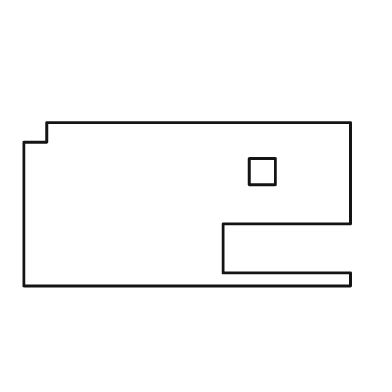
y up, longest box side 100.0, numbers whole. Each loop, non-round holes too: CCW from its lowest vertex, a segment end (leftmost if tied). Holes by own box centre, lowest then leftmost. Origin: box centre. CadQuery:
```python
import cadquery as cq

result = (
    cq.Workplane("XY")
    .moveTo(-50.0, -25.0)
    .lineTo(50.0, -25.0)
    .lineTo(50.0, -21.0)
    .lineTo(11.0, -21.0)
    .lineTo(11.0, -6.0)
    .lineTo(50.0, -6.0)
    .lineTo(50.0, 25.0)
    .lineTo(-43.0, 25.0)
    .lineTo(-43.0, 19.0)
    .lineTo(-50.0, 19.0)
    .close()
    .moveTo(19.0, 6.0)
    .lineTo(27.0, 6.0)
    .lineTo(27.0, 14.0)
    .lineTo(19.0, 14.0)
    .close()
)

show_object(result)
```